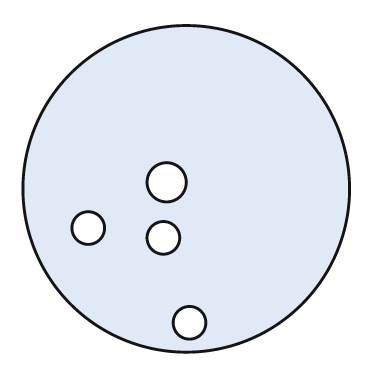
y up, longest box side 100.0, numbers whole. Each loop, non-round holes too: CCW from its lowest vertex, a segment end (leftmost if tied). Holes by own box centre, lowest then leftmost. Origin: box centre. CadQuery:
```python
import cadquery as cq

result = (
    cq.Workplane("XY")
    .moveTo(0.0, 0.0)
    .circle(50.0)
    .moveTo(1.0, -41.0)
    .circle(5.0)
    .moveTo(-7.0, -15.0)
    .circle(5.0)
    .moveTo(-30.0, -12.0)
    .circle(5.0)
    .moveTo(-6.0, 2.0)
    .circle(6.0)
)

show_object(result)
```